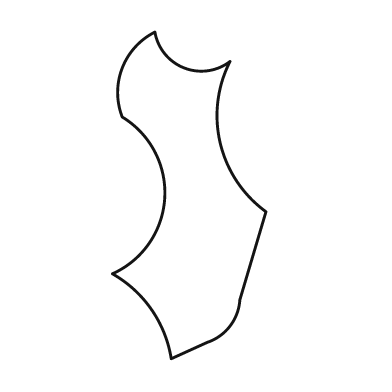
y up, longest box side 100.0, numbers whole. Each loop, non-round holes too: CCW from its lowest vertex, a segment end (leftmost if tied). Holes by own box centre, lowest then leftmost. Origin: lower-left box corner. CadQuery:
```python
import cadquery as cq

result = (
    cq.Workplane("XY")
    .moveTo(18.0, 0.0)
    .lineTo(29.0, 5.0)
    .threePointArc((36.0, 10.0), (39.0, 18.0))
    .lineTo(47.0, 45.0)
    .threePointArc((33.0, 66.0), (36.0, 91.0))
    .threePointArc((22.0, 89.0), (13.0, 100.0))
    .threePointArc((3.0, 89.0), (3.0, 74.0))
    .threePointArc((16.0, 49.0), (0.0, 26.0))
    .threePointArc((12.0, 15.0), (18.0, 0.0))
    .close()
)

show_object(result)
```